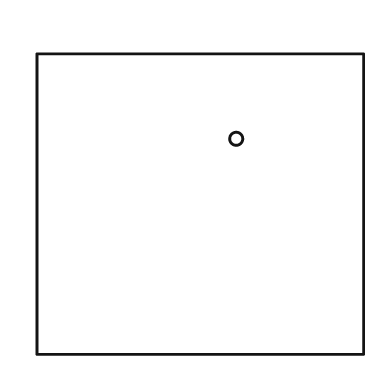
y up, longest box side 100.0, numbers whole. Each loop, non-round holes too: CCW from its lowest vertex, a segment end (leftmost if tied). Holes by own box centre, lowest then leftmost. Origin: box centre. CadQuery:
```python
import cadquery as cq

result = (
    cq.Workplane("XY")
    .moveTo(-50.0, -46.0)
    .lineTo(50.0, -46.0)
    .lineTo(50.0, 46.0)
    .lineTo(-50.0, 46.0)
    .close()
    .moveTo(11.0, 20.0)
    .circle(2.0)
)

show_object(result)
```